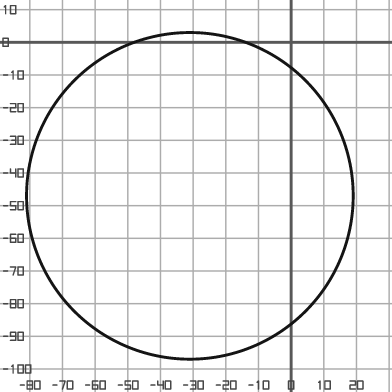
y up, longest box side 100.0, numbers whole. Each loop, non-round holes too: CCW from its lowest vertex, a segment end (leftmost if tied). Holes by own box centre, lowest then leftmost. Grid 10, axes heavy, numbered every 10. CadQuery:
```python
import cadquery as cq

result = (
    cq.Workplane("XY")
    .moveTo(-31.0, -47.0)
    .circle(50.0)
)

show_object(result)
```